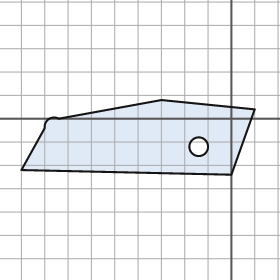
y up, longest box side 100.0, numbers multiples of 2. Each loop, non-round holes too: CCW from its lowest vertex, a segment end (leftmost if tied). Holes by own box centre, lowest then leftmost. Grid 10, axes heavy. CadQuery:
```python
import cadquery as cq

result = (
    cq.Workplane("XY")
    .moveTo(0.0, -24.0)
    .lineTo(10.0, 4.0)
    .lineTo(-30.0, 8.0)
    .lineTo(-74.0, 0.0)
    .threePointArc((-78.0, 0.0), (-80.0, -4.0))
    .lineTo(-90.0, -22.0)
    .close()
    .moveTo(-14.0, -12.0)
    .circle(4.0)
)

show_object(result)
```